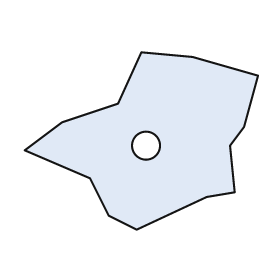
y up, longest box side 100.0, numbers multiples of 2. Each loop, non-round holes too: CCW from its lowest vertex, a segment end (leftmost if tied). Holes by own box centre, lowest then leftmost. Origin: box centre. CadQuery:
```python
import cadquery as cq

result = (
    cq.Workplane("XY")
    .moveTo(-2.0, -38.0)
    .lineTo(28.0, -24.0)
    .lineTo(40.0, -22.0)
    .lineTo(38.0, -2.0)
    .lineTo(44.0, 6.0)
    .lineTo(50.0, 28.0)
    .lineTo(22.0, 36.0)
    .lineTo(0.0, 38.0)
    .lineTo(-10.0, 16.0)
    .lineTo(-34.0, 8.0)
    .lineTo(-50.0, -4.0)
    .lineTo(-22.0, -16.0)
    .lineTo(-14.0, -32.0)
    .close()
    .moveTo(2.0, -2.0)
    .circle(6.0)
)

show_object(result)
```